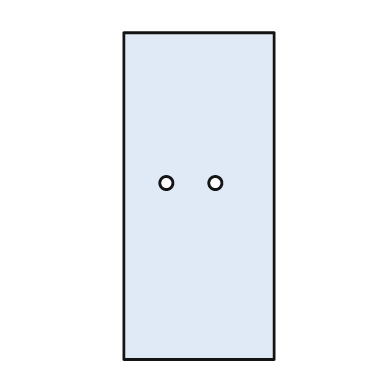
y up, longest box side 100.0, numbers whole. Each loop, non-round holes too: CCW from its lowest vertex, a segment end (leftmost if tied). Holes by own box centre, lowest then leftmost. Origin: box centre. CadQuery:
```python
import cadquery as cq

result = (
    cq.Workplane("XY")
    .moveTo(-23.0, -50.0)
    .lineTo(23.0, -50.0)
    .lineTo(23.0, 50.0)
    .lineTo(-23.0, 50.0)
    .close()
    .moveTo(-10.0, 4.0)
    .circle(2.0)
    .moveTo(5.0, 4.0)
    .circle(2.0)
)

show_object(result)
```